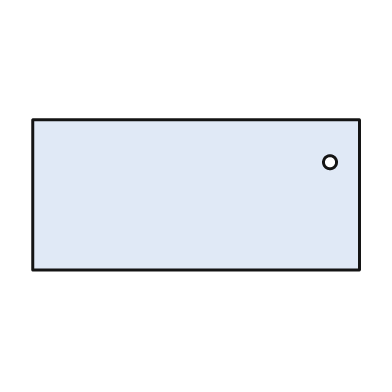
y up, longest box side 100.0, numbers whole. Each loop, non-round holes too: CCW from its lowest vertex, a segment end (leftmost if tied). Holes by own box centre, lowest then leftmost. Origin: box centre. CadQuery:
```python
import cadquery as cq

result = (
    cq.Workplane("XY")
    .moveTo(-50.0, -23.0)
    .lineTo(50.0, -23.0)
    .lineTo(50.0, 23.0)
    .lineTo(-50.0, 23.0)
    .close()
    .moveTo(41.0, 10.0)
    .circle(2.0)
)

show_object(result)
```